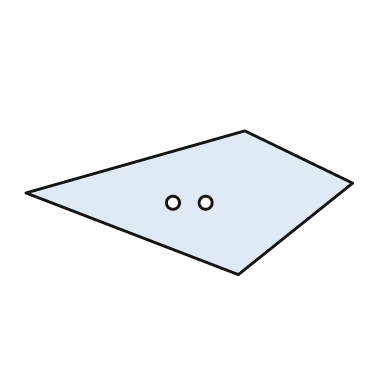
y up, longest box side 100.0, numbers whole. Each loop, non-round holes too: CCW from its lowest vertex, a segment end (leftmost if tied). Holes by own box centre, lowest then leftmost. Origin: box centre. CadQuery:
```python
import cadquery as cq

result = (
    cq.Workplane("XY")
    .moveTo(15.0, -22.0)
    .lineTo(50.0, 6.0)
    .lineTo(17.0, 22.0)
    .lineTo(-50.0, 3.0)
    .close()
    .moveTo(-5.0, 0.0)
    .circle(2.0)
    .moveTo(5.0, 0.0)
    .circle(2.0)
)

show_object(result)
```